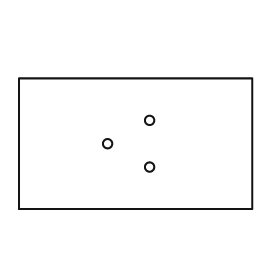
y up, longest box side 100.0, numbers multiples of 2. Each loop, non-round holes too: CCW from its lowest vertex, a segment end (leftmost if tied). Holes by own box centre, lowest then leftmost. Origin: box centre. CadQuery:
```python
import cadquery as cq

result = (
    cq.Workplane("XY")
    .moveTo(-50.0, -28.0)
    .lineTo(50.0, -28.0)
    .lineTo(50.0, 28.0)
    .lineTo(-50.0, 28.0)
    .close()
    .moveTo(6.0, -10.0)
    .circle(2.0)
    .moveTo(-12.0, 0.0)
    .circle(2.0)
    .moveTo(6.0, 10.0)
    .circle(2.0)
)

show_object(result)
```